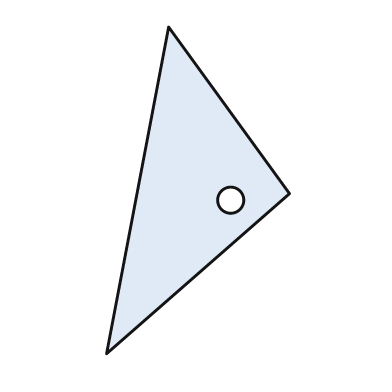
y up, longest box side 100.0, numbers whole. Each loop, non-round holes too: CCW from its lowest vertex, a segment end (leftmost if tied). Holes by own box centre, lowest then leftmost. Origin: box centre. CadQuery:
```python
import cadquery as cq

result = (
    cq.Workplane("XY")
    .moveTo(-28.0, -50.0)
    .lineTo(28.0, -1.0)
    .lineTo(-9.0, 50.0)
    .close()
    .moveTo(10.0, -3.0)
    .circle(4.0)
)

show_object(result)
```